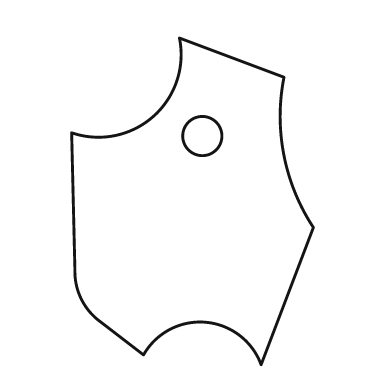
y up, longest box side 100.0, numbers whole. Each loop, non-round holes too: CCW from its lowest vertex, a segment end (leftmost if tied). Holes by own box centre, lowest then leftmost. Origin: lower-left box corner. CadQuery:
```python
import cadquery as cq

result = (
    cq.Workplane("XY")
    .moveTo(58.0, 0.0)
    .lineTo(74.0, 42.0)
    .threePointArc((65.0, 64.0), (65.0, 88.0))
    .lineTo(33.0, 100.0)
    .threePointArc((25.0, 76.0), (0.0, 71.0))
    .lineTo(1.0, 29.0)
    .threePointArc((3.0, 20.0), (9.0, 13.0))
    .lineTo(22.0, 3.0)
    .threePointArc((41.0, 13.0), (58.0, 0.0))
    .close()
    .moveTo(40.0, 70.0)
    .circle(6.0)
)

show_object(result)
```